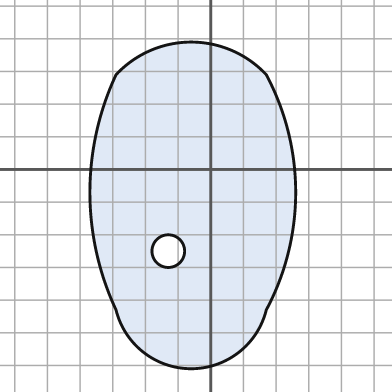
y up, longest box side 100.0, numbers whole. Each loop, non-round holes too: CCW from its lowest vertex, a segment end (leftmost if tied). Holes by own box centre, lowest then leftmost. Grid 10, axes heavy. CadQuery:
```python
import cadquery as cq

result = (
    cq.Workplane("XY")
    .moveTo(-29.0, -43.0)
    .threePointArc((-6.0, -61.0), (17.0, -43.0))
    .threePointArc((26.0, -7.0), (17.0, 29.0))
    .threePointArc((-6.0, 39.0), (-29.0, 29.0))
    .threePointArc((-37.0, -7.0), (-29.0, -43.0))
    .close()
    .moveTo(-13.0, -25.0)
    .circle(5.0)
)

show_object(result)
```